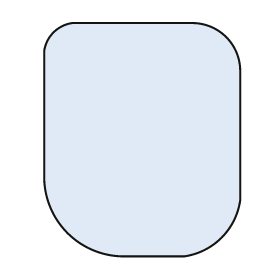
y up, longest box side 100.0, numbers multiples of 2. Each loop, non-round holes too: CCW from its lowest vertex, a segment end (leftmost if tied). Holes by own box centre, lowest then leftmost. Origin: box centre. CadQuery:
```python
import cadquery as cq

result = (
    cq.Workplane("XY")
    .moveTo(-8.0, -50.0)
    .lineTo(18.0, -50.0)
    .threePointArc((34.0, -42.0), (42.0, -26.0))
    .lineTo(42.0, 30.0)
    .threePointArc((36.0, 44.0), (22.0, 50.0))
    .lineTo(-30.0, 50.0)
    .threePointArc((-38.0, 46.0), (-42.0, 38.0))
    .lineTo(-42.0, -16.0)
    .threePointArc((-32.0, -40.0), (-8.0, -50.0))
    .close()
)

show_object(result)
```